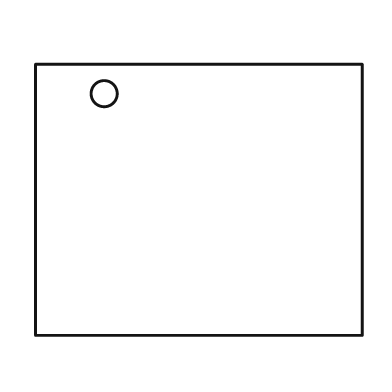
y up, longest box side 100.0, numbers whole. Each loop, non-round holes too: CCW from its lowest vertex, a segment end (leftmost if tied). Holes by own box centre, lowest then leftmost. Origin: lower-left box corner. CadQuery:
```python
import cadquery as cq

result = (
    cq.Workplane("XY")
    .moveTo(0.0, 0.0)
    .lineTo(100.0, 0.0)
    .lineTo(100.0, 83.0)
    .lineTo(0.0, 83.0)
    .close()
    .moveTo(21.0, 74.0)
    .circle(4.0)
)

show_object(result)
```